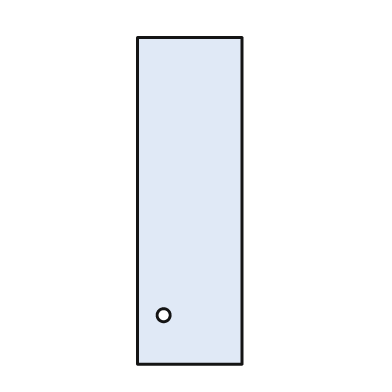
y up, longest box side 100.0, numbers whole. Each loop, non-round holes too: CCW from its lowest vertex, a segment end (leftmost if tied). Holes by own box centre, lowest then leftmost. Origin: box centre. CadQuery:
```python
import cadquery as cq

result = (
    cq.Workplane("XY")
    .moveTo(-16.0, -50.0)
    .lineTo(16.0, -50.0)
    .lineTo(16.0, 50.0)
    .lineTo(-16.0, 50.0)
    .close()
    .moveTo(-8.0, -35.0)
    .circle(2.0)
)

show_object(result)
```